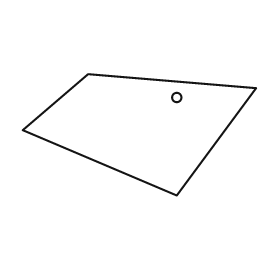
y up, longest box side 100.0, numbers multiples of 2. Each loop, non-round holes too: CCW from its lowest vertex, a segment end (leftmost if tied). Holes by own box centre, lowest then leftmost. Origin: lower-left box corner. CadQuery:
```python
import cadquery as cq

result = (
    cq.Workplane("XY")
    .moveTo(66.0, 0.0)
    .lineTo(100.0, 46.0)
    .lineTo(28.0, 52.0)
    .lineTo(0.0, 28.0)
    .close()
    .moveTo(66.0, 42.0)
    .circle(2.0)
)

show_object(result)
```